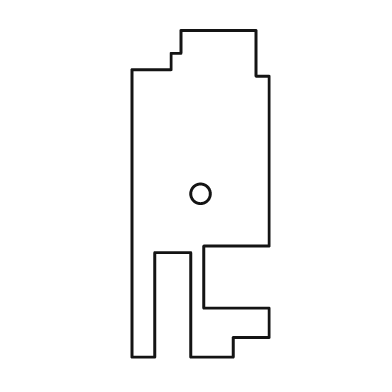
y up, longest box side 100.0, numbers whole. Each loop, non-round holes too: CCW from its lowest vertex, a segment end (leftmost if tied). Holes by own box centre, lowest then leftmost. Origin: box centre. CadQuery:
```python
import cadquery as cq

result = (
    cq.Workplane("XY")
    .moveTo(-21.0, -50.0)
    .lineTo(-14.0, -50.0)
    .lineTo(-14.0, -18.0)
    .lineTo(-3.0, -18.0)
    .lineTo(-3.0, -50.0)
    .lineTo(10.0, -50.0)
    .lineTo(10.0, -44.0)
    .lineTo(21.0, -44.0)
    .lineTo(21.0, -35.0)
    .lineTo(1.0, -35.0)
    .lineTo(1.0, -16.0)
    .lineTo(21.0, -16.0)
    .lineTo(21.0, 36.0)
    .lineTo(17.0, 36.0)
    .lineTo(17.0, 50.0)
    .lineTo(-6.0, 50.0)
    .lineTo(-6.0, 43.0)
    .lineTo(-9.0, 43.0)
    .lineTo(-9.0, 38.0)
    .lineTo(-21.0, 38.0)
    .close()
    .moveTo(0.0, 0.0)
    .circle(3.0)
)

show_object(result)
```